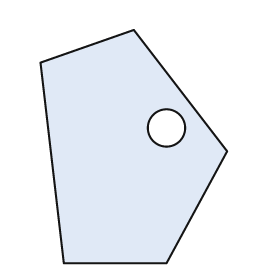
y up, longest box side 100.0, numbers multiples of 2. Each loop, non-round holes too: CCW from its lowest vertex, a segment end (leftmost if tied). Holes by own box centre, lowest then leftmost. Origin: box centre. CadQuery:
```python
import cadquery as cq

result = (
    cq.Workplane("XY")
    .moveTo(-30.0, -50.0)
    .lineTo(14.0, -50.0)
    .lineTo(40.0, -2.0)
    .lineTo(0.0, 50.0)
    .lineTo(-40.0, 36.0)
    .close()
    .moveTo(14.0, 8.0)
    .circle(8.0)
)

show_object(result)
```